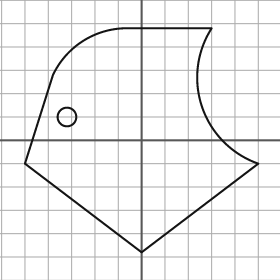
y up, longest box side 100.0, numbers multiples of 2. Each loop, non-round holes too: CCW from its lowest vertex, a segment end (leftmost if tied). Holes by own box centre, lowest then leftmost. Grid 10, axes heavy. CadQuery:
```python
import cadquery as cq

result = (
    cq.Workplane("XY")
    .moveTo(0.0, -48.0)
    .lineTo(50.0, -10.0)
    .threePointArc((26.0, 14.0), (30.0, 48.0))
    .lineTo(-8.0, 48.0)
    .threePointArc((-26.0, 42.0), (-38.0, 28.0))
    .lineTo(-50.0, -10.0)
    .close()
    .moveTo(-32.0, 10.0)
    .circle(4.0)
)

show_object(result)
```